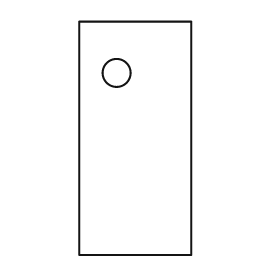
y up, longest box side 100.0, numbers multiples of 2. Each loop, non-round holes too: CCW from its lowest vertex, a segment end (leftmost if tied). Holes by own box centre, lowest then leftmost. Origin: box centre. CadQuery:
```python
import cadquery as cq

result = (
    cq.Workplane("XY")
    .moveTo(-24.0, -50.0)
    .lineTo(24.0, -50.0)
    .lineTo(24.0, 50.0)
    .lineTo(-24.0, 50.0)
    .close()
    .moveTo(-8.0, 28.0)
    .circle(6.0)
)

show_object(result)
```